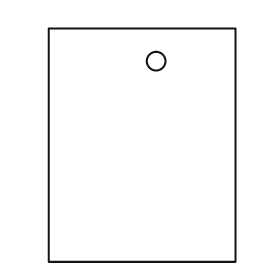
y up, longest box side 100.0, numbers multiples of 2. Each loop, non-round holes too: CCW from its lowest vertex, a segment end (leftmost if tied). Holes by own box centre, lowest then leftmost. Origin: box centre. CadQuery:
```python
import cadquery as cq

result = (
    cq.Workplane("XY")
    .moveTo(-40.0, -50.0)
    .lineTo(40.0, -50.0)
    .lineTo(40.0, 50.0)
    .lineTo(-40.0, 50.0)
    .close()
    .moveTo(6.0, 36.0)
    .circle(4.0)
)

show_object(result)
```